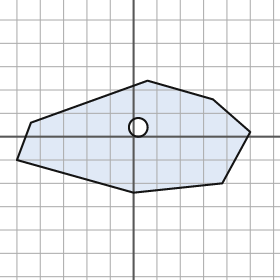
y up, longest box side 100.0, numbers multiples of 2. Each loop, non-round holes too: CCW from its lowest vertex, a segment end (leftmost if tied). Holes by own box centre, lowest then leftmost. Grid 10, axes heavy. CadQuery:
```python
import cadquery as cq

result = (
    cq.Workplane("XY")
    .moveTo(0.0, -24.0)
    .lineTo(38.0, -20.0)
    .lineTo(50.0, 2.0)
    .lineTo(34.0, 16.0)
    .lineTo(6.0, 24.0)
    .lineTo(-44.0, 6.0)
    .lineTo(-50.0, -10.0)
    .close()
    .moveTo(2.0, 4.0)
    .circle(4.0)
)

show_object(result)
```